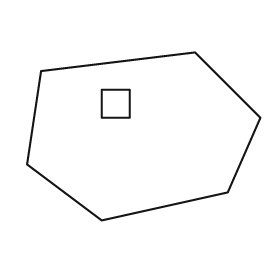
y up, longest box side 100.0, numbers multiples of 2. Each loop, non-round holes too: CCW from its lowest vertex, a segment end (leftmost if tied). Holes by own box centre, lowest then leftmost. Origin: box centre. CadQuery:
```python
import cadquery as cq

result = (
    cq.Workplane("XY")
    .moveTo(-18.0, -36.0)
    .lineTo(36.0, -24.0)
    .lineTo(50.0, 8.0)
    .lineTo(22.0, 36.0)
    .lineTo(-44.0, 28.0)
    .lineTo(-50.0, -12.0)
    .close()
    .moveTo(-18.0, 8.0)
    .lineTo(-6.0, 8.0)
    .lineTo(-6.0, 20.0)
    .lineTo(-18.0, 20.0)
    .close()
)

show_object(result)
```